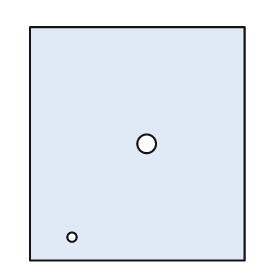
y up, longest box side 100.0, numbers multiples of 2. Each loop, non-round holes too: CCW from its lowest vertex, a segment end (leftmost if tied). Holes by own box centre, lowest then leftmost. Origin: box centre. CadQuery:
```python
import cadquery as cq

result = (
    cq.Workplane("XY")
    .moveTo(-46.0, -50.0)
    .lineTo(46.0, -50.0)
    .lineTo(46.0, 50.0)
    .lineTo(-46.0, 50.0)
    .close()
    .moveTo(-28.0, -40.0)
    .circle(2.0)
    .moveTo(4.0, 0.0)
    .circle(4.0)
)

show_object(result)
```